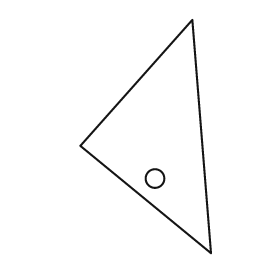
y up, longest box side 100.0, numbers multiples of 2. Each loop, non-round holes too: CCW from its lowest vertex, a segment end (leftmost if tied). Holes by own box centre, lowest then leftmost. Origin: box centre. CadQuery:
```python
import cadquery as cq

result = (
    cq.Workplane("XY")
    .moveTo(28.0, -50.0)
    .lineTo(20.0, 50.0)
    .lineTo(-28.0, -4.0)
    .close()
    .moveTo(4.0, -18.0)
    .circle(4.0)
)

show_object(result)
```